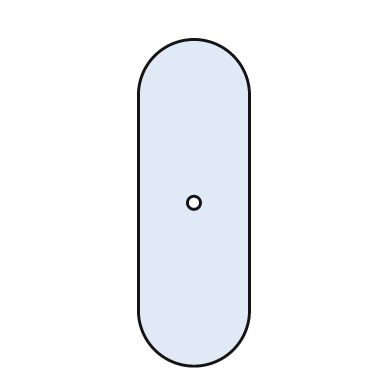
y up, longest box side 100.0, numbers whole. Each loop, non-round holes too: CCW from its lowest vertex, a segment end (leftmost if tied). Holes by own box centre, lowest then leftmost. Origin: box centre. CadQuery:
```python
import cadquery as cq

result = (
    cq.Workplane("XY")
    .moveTo(-17.0, -33.0)
    .threePointArc((0.0, -50.0), (17.0, -33.0))
    .lineTo(17.0, 33.0)
    .threePointArc((0.0, 50.0), (-17.0, 33.0))
    .close()
    .moveTo(0.0, 0.0)
    .circle(2.0)
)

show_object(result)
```